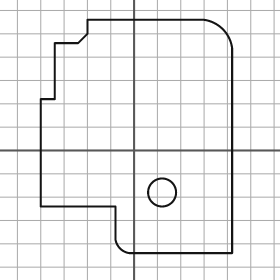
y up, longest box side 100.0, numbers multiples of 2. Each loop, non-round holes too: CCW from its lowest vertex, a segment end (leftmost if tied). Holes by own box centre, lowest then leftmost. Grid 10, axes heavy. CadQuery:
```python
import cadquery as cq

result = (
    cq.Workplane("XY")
    .moveTo(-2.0, -44.0)
    .lineTo(42.0, -44.0)
    .lineTo(42.0, 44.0)
    .threePointArc((38.0, 52.0), (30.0, 56.0))
    .lineTo(-20.0, 56.0)
    .lineTo(-20.0, 50.0)
    .lineTo(-24.0, 46.0)
    .lineTo(-34.0, 46.0)
    .lineTo(-34.0, 22.0)
    .lineTo(-40.0, 22.0)
    .lineTo(-40.0, -24.0)
    .lineTo(-8.0, -24.0)
    .lineTo(-8.0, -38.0)
    .threePointArc((-6.0, -42.0), (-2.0, -44.0))
    .close()
    .moveTo(12.0, -18.0)
    .circle(6.0)
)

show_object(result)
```